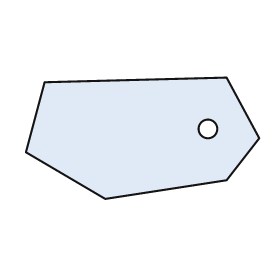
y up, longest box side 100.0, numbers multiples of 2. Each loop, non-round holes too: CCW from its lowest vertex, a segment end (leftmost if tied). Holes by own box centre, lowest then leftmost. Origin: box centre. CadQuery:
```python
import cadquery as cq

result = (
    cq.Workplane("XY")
    .moveTo(-16.0, -26.0)
    .lineTo(36.0, -18.0)
    .lineTo(50.0, 0.0)
    .lineTo(36.0, 26.0)
    .lineTo(-42.0, 24.0)
    .lineTo(-50.0, -6.0)
    .close()
    .moveTo(28.0, 4.0)
    .circle(4.0)
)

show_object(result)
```